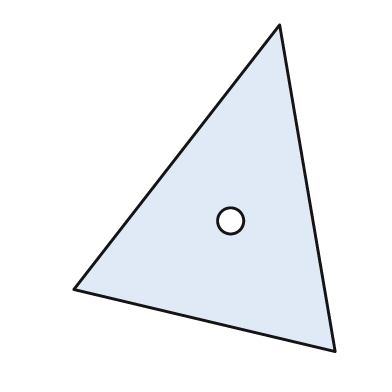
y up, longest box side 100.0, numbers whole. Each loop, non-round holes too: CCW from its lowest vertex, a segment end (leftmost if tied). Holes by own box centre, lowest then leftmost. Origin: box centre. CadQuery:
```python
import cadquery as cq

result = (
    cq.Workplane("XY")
    .moveTo(40.0, -50.0)
    .lineTo(23.0, 50.0)
    .lineTo(-40.0, -31.0)
    .close()
    .moveTo(8.0, -10.0)
    .circle(4.0)
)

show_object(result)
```